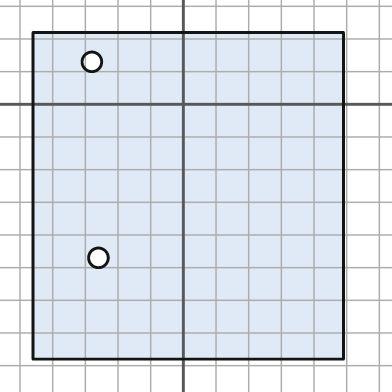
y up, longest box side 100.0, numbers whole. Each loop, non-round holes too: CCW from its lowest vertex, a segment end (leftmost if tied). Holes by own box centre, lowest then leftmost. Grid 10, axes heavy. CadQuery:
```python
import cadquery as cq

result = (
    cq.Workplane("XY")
    .moveTo(-46.0, -78.0)
    .lineTo(49.0, -78.0)
    .lineTo(49.0, 22.0)
    .lineTo(-46.0, 22.0)
    .close()
    .moveTo(-26.0, -47.0)
    .circle(3.0)
    .moveTo(-28.0, 13.0)
    .circle(3.0)
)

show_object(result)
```